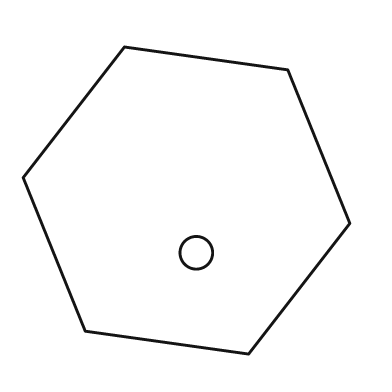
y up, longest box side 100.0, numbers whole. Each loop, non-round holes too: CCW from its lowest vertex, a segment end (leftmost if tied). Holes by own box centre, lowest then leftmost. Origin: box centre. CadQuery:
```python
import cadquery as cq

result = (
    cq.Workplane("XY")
    .moveTo(19.0, -47.0)
    .lineTo(50.0, -7.0)
    .lineTo(31.0, 40.0)
    .lineTo(-19.0, 47.0)
    .lineTo(-50.0, 7.0)
    .lineTo(-31.0, -40.0)
    .close()
    .moveTo(3.0, -16.0)
    .circle(5.0)
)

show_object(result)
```